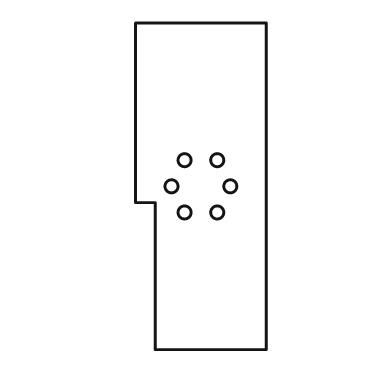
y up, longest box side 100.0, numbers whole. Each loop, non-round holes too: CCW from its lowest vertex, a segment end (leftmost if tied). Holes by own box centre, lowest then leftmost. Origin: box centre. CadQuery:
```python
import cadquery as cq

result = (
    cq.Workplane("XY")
    .moveTo(-14.0, -50.0)
    .lineTo(20.0, -50.0)
    .lineTo(20.0, 50.0)
    .lineTo(-20.0, 50.0)
    .lineTo(-20.0, -5.0)
    .lineTo(-14.0, -5.0)
    .close()
    .moveTo(-5.0, -8.0)
    .circle(2.0)
    .moveTo(5.0, -8.0)
    .circle(2.0)
    .moveTo(-9.0, 0.0)
    .circle(2.0)
    .moveTo(9.0, 0.0)
    .circle(2.0)
    .moveTo(-5.0, 8.0)
    .circle(2.0)
    .moveTo(5.0, 8.0)
    .circle(2.0)
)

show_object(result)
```